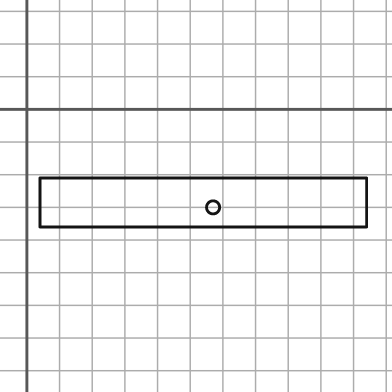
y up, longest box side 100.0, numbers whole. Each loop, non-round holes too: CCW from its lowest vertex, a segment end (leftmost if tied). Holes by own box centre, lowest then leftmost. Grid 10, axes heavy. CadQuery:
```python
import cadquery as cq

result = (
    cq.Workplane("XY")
    .moveTo(4.0, -36.0)
    .lineTo(104.0, -36.0)
    .lineTo(104.0, -21.0)
    .lineTo(4.0, -21.0)
    .close()
    .moveTo(57.0, -30.0)
    .circle(2.0)
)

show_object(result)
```